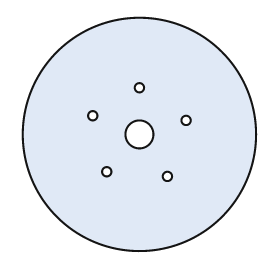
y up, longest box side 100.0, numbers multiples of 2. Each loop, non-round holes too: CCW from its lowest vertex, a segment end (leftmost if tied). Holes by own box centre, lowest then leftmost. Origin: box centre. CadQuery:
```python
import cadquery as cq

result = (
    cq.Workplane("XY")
    .moveTo(0.0, 0.0)
    .circle(50.0)
    .moveTo(12.0, -18.0)
    .circle(2.0)
    .moveTo(-14.0, -16.0)
    .circle(2.0)
    .moveTo(0.0, 0.0)
    .circle(6.0)
    .moveTo(20.0, 6.0)
    .circle(2.0)
    .moveTo(-20.0, 8.0)
    .circle(2.0)
    .moveTo(0.0, 20.0)
    .circle(2.0)
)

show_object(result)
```